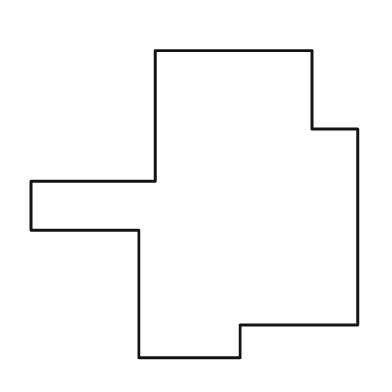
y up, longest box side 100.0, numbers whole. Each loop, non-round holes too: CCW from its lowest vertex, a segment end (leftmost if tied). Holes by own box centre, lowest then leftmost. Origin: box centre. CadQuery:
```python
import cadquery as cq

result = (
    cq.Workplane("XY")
    .moveTo(-17.0, -47.0)
    .lineTo(14.0, -47.0)
    .lineTo(14.0, -37.0)
    .lineTo(50.0, -37.0)
    .lineTo(50.0, 23.0)
    .lineTo(36.0, 23.0)
    .lineTo(36.0, 47.0)
    .lineTo(-12.0, 47.0)
    .lineTo(-12.0, 7.0)
    .lineTo(-50.0, 7.0)
    .lineTo(-50.0, -8.0)
    .lineTo(-17.0, -8.0)
    .close()
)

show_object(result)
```